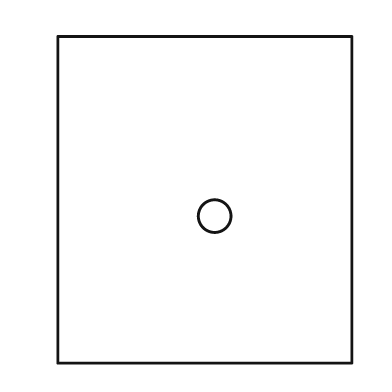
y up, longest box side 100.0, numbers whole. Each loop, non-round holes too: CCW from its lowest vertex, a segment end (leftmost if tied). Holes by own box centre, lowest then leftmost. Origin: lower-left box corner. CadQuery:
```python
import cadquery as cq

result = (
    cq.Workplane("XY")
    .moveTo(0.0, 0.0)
    .lineTo(90.0, 0.0)
    .lineTo(90.0, 100.0)
    .lineTo(0.0, 100.0)
    .close()
    .moveTo(48.0, 45.0)
    .circle(5.0)
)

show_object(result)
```